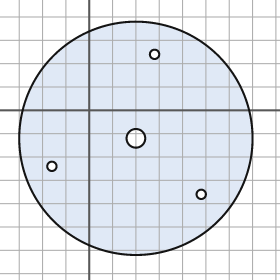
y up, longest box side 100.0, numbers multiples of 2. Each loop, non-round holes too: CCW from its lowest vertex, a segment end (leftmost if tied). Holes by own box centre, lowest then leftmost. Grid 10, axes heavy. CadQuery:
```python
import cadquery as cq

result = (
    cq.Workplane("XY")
    .moveTo(20.0, -12.0)
    .circle(50.0)
    .moveTo(48.0, -36.0)
    .circle(2.0)
    .moveTo(-16.0, -24.0)
    .circle(2.0)
    .moveTo(20.0, -12.0)
    .circle(4.0)
    .moveTo(28.0, 24.0)
    .circle(2.0)
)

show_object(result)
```